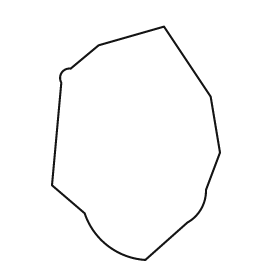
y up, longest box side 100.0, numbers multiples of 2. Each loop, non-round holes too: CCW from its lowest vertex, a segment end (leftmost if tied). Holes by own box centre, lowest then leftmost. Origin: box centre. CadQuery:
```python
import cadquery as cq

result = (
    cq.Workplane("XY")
    .moveTo(4.0, -50.0)
    .lineTo(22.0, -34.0)
    .threePointArc((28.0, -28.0), (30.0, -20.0))
    .lineTo(36.0, -4.0)
    .lineTo(32.0, 20.0)
    .lineTo(12.0, 50.0)
    .lineTo(-16.0, 42.0)
    .lineTo(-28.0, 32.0)
    .threePointArc((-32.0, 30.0), (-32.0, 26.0))
    .lineTo(-36.0, -18.0)
    .lineTo(-22.0, -30.0)
    .threePointArc((-12.0, -44.0), (4.0, -50.0))
    .close()
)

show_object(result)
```